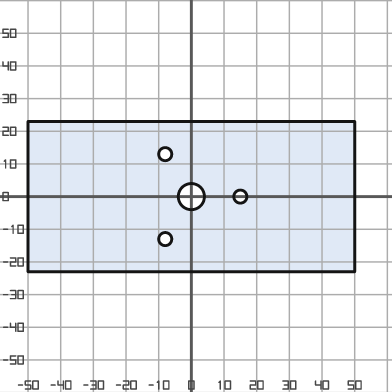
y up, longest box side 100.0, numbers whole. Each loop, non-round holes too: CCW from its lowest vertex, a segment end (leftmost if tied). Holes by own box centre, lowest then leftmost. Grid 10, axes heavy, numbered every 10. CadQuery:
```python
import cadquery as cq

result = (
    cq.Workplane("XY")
    .moveTo(-50.0, -23.0)
    .lineTo(50.0, -23.0)
    .lineTo(50.0, 23.0)
    .lineTo(-50.0, 23.0)
    .close()
    .moveTo(-8.0, -13.0)
    .circle(2.0)
    .moveTo(0.0, 0.0)
    .circle(4.0)
    .moveTo(15.0, 0.0)
    .circle(2.0)
    .moveTo(-8.0, 13.0)
    .circle(2.0)
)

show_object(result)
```